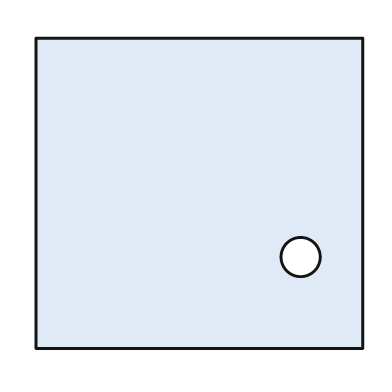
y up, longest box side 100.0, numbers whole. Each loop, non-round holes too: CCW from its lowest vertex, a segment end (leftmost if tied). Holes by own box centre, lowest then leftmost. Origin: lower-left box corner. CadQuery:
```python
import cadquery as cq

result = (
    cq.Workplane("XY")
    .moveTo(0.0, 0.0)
    .lineTo(100.0, 0.0)
    .lineTo(100.0, 95.0)
    .lineTo(0.0, 95.0)
    .close()
    .moveTo(81.0, 28.0)
    .circle(6.0)
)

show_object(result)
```